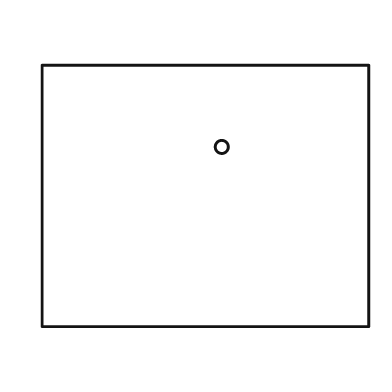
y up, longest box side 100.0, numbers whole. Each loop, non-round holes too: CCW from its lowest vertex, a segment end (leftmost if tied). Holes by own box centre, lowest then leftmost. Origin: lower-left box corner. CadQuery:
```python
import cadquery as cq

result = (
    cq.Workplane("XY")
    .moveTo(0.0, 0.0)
    .lineTo(100.0, 0.0)
    .lineTo(100.0, 80.0)
    .lineTo(0.0, 80.0)
    .close()
    .moveTo(55.0, 55.0)
    .circle(2.0)
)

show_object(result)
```